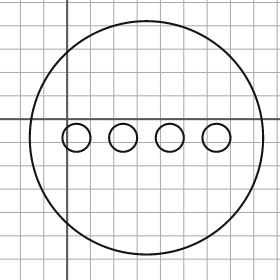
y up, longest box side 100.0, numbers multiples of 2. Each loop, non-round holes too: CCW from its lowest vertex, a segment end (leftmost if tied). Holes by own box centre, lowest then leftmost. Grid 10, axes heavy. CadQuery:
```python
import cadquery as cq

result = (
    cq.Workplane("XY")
    .moveTo(34.0, -8.0)
    .circle(50.0)
    .moveTo(4.0, -8.0)
    .circle(6.0)
    .moveTo(24.0, -8.0)
    .circle(6.0)
    .moveTo(44.0, -8.0)
    .circle(6.0)
    .moveTo(64.0, -8.0)
    .circle(6.0)
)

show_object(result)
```